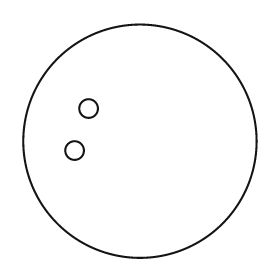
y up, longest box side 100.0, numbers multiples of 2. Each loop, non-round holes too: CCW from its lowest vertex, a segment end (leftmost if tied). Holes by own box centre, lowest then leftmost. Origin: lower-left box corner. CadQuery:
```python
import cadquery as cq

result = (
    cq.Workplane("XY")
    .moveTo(50.0, 50.0)
    .circle(50.0)
    .moveTo(22.0, 46.0)
    .circle(4.0)
    .moveTo(28.0, 64.0)
    .circle(4.0)
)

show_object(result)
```